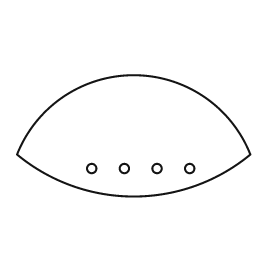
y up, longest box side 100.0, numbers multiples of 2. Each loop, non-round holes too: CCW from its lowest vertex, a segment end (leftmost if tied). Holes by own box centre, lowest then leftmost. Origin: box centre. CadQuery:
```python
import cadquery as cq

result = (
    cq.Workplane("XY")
    .moveTo(-50.0, -8.0)
    .threePointArc((0.0, -26.0), (50.0, -8.0))
    .threePointArc((0.0, 26.0), (-50.0, -8.0))
    .close()
    .moveTo(-18.0, -14.0)
    .circle(2.0)
    .moveTo(-4.0, -14.0)
    .circle(2.0)
    .moveTo(10.0, -14.0)
    .circle(2.0)
    .moveTo(24.0, -14.0)
    .circle(2.0)
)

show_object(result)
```